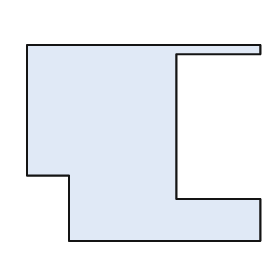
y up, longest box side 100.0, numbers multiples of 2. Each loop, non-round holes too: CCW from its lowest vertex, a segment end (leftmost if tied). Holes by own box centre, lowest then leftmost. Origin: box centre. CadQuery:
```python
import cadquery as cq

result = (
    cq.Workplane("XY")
    .moveTo(-32.0, -42.0)
    .lineTo(50.0, -42.0)
    .lineTo(50.0, -24.0)
    .lineTo(14.0, -24.0)
    .lineTo(14.0, 38.0)
    .lineTo(50.0, 38.0)
    .lineTo(50.0, 42.0)
    .lineTo(-50.0, 42.0)
    .lineTo(-50.0, -14.0)
    .lineTo(-32.0, -14.0)
    .close()
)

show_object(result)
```